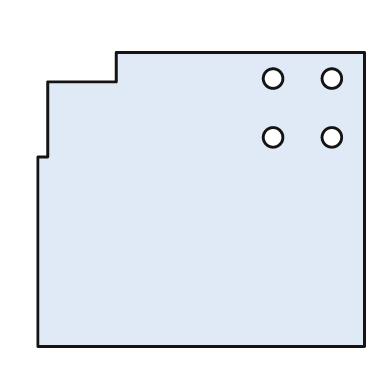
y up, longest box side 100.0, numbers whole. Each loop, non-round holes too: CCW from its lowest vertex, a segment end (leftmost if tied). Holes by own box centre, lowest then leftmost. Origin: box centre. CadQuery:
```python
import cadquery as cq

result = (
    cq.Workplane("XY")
    .moveTo(-50.0, -45.0)
    .lineTo(50.0, -45.0)
    .lineTo(50.0, 45.0)
    .lineTo(-26.0, 45.0)
    .lineTo(-26.0, 36.0)
    .lineTo(-47.0, 36.0)
    .lineTo(-47.0, 13.0)
    .lineTo(-50.0, 13.0)
    .close()
    .moveTo(22.0, 19.0)
    .circle(3.0)
    .moveTo(40.0, 19.0)
    .circle(3.0)
    .moveTo(22.0, 37.0)
    .circle(3.0)
    .moveTo(40.0, 37.0)
    .circle(3.0)
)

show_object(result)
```